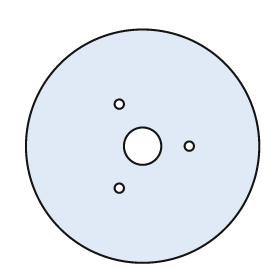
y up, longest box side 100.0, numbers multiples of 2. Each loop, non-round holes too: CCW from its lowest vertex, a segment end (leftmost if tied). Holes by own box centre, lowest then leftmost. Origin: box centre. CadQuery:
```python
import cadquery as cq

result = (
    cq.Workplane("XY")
    .moveTo(0.0, 0.0)
    .circle(50.0)
    .moveTo(-10.0, -18.0)
    .circle(2.0)
    .moveTo(0.0, 0.0)
    .circle(8.0)
    .moveTo(20.0, 0.0)
    .circle(2.0)
    .moveTo(-10.0, 18.0)
    .circle(2.0)
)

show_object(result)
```